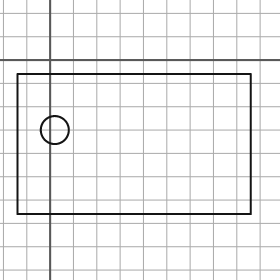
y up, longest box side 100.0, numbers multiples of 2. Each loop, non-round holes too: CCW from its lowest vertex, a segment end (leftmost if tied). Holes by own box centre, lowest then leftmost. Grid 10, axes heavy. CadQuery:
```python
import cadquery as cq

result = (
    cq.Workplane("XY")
    .moveTo(-14.0, -66.0)
    .lineTo(86.0, -66.0)
    .lineTo(86.0, -6.0)
    .lineTo(-14.0, -6.0)
    .close()
    .moveTo(2.0, -30.0)
    .circle(6.0)
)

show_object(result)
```